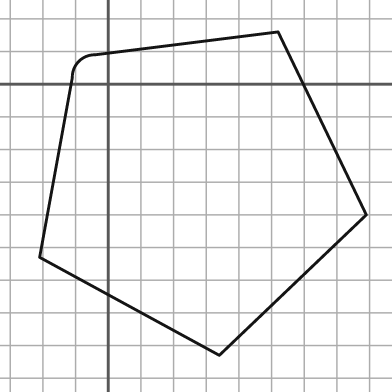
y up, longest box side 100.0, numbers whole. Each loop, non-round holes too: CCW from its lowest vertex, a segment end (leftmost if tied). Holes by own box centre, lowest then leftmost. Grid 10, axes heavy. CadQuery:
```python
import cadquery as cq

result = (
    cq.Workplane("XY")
    .moveTo(34.0, -83.0)
    .lineTo(79.0, -40.0)
    .lineTo(52.0, 16.0)
    .lineTo(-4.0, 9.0)
    .threePointArc((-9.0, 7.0), (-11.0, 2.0))
    .lineTo(-21.0, -53.0)
    .close()
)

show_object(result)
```